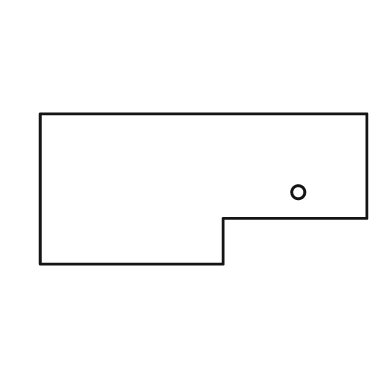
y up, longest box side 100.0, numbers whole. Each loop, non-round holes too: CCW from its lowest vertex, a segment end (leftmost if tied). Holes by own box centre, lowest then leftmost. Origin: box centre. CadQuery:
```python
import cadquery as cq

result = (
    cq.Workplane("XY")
    .moveTo(-50.0, -23.0)
    .lineTo(6.0, -23.0)
    .lineTo(6.0, -9.0)
    .lineTo(50.0, -9.0)
    .lineTo(50.0, 23.0)
    .lineTo(-50.0, 23.0)
    .close()
    .moveTo(29.0, -1.0)
    .circle(2.0)
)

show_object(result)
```